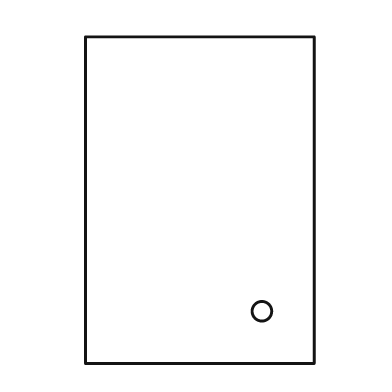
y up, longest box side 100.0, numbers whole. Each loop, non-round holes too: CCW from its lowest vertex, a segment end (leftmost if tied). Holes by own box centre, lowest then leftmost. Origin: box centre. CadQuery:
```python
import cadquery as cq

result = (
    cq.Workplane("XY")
    .moveTo(-35.0, -50.0)
    .lineTo(35.0, -50.0)
    .lineTo(35.0, 50.0)
    .lineTo(-35.0, 50.0)
    .close()
    .moveTo(19.0, -34.0)
    .circle(3.0)
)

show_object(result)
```